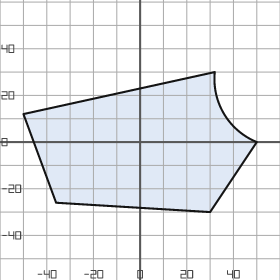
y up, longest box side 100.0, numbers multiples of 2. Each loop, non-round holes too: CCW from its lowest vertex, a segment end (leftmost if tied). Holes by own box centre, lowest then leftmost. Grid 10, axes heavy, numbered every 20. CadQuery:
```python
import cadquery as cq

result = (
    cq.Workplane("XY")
    .moveTo(30.0, -30.0)
    .lineTo(50.0, 0.0)
    .threePointArc((36.0, 12.0), (32.0, 30.0))
    .lineTo(-50.0, 12.0)
    .lineTo(-36.0, -26.0)
    .close()
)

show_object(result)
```